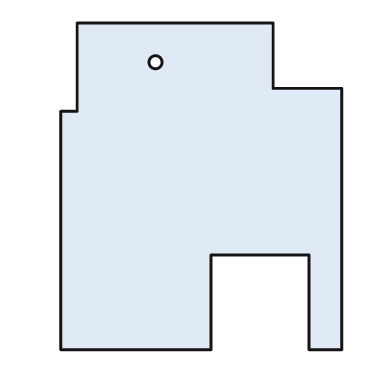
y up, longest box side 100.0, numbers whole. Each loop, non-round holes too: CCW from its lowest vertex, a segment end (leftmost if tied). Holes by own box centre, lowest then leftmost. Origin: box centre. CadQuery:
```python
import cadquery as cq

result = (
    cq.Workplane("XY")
    .moveTo(-43.0, -50.0)
    .lineTo(3.0, -50.0)
    .lineTo(3.0, -21.0)
    .lineTo(33.0, -21.0)
    .lineTo(33.0, -50.0)
    .lineTo(43.0, -50.0)
    .lineTo(43.0, 30.0)
    .lineTo(22.0, 30.0)
    .lineTo(22.0, 50.0)
    .lineTo(-38.0, 50.0)
    .lineTo(-38.0, 23.0)
    .lineTo(-43.0, 23.0)
    .close()
    .moveTo(-14.0, 38.0)
    .circle(2.0)
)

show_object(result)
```